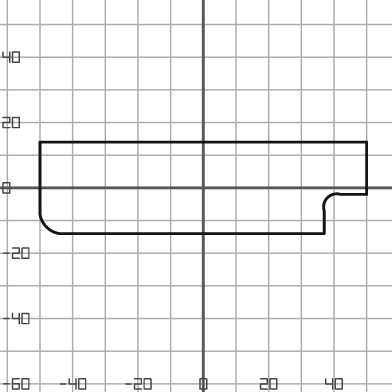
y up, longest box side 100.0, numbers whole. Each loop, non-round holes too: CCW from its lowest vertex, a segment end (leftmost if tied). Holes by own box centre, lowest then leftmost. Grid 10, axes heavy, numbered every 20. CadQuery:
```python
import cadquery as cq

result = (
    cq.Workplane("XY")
    .moveTo(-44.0, -14.0)
    .lineTo(37.0, -14.0)
    .lineTo(37.0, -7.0)
    .threePointArc((38.0, -3.0), (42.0, -2.0))
    .lineTo(50.0, -2.0)
    .lineTo(50.0, 14.0)
    .lineTo(-50.0, 14.0)
    .lineTo(-50.0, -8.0)
    .threePointArc((-48.0, -12.0), (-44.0, -14.0))
    .close()
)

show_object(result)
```